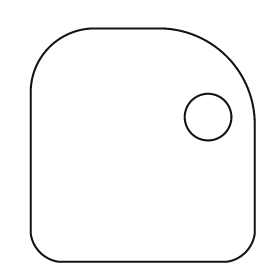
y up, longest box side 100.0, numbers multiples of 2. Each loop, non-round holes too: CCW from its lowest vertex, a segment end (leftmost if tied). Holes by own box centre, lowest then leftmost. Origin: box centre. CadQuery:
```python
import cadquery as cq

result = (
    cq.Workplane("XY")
    .moveTo(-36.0, -50.0)
    .lineTo(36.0, -50.0)
    .threePointArc((44.0, -46.0), (48.0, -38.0))
    .lineTo(48.0, 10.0)
    .threePointArc((36.0, 38.0), (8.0, 50.0))
    .lineTo(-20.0, 50.0)
    .threePointArc((-40.0, 42.0), (-48.0, 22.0))
    .lineTo(-48.0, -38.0)
    .threePointArc((-44.0, -46.0), (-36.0, -50.0))
    .close()
    .moveTo(28.0, 12.0)
    .circle(10.0)
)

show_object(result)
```